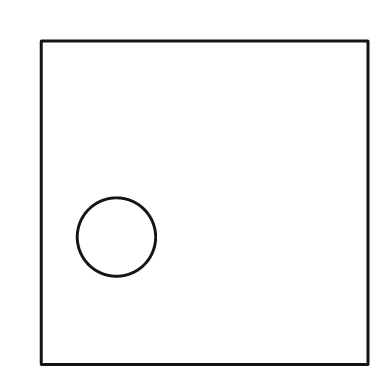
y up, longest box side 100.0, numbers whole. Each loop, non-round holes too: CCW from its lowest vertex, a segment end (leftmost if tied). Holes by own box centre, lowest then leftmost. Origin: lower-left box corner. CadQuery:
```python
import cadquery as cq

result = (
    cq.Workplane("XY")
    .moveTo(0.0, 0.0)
    .lineTo(100.0, 0.0)
    .lineTo(100.0, 99.0)
    .lineTo(0.0, 99.0)
    .close()
    .moveTo(23.0, 39.0)
    .circle(12.0)
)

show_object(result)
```